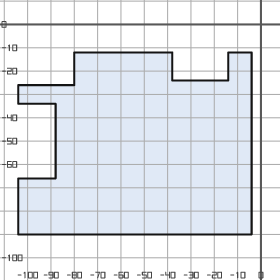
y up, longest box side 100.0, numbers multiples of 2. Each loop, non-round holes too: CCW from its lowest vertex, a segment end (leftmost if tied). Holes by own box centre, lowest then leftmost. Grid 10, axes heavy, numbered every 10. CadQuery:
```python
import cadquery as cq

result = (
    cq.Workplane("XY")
    .moveTo(-104.0, -90.0)
    .lineTo(-4.0, -90.0)
    .lineTo(-4.0, -12.0)
    .lineTo(-14.0, -12.0)
    .lineTo(-14.0, -24.0)
    .lineTo(-38.0, -24.0)
    .lineTo(-38.0, -12.0)
    .lineTo(-80.0, -12.0)
    .lineTo(-80.0, -26.0)
    .lineTo(-104.0, -26.0)
    .lineTo(-104.0, -34.0)
    .lineTo(-88.0, -34.0)
    .lineTo(-88.0, -66.0)
    .lineTo(-104.0, -66.0)
    .close()
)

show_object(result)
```